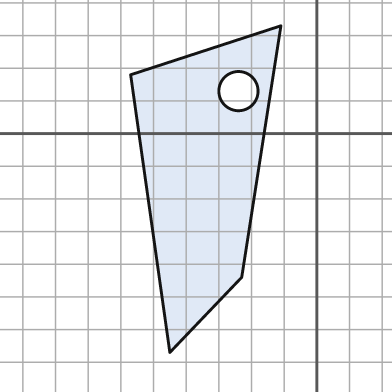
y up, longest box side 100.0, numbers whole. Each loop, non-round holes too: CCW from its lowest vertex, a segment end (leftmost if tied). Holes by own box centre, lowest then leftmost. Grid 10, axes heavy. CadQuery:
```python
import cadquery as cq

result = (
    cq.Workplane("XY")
    .moveTo(-45.0, -67.0)
    .lineTo(-23.0, -44.0)
    .lineTo(-11.0, 33.0)
    .lineTo(-57.0, 18.0)
    .close()
    .moveTo(-24.0, 13.0)
    .circle(6.0)
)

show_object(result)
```